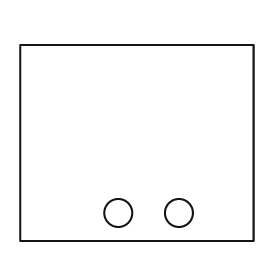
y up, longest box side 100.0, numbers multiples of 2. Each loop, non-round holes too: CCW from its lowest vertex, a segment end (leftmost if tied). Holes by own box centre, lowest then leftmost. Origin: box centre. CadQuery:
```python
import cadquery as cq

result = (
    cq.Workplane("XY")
    .moveTo(-50.0, -42.0)
    .lineTo(50.0, -42.0)
    .lineTo(50.0, 42.0)
    .lineTo(-50.0, 42.0)
    .close()
    .moveTo(-8.0, -30.0)
    .circle(6.0)
    .moveTo(18.0, -30.0)
    .circle(6.0)
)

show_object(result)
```